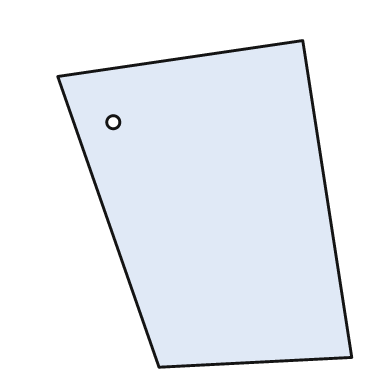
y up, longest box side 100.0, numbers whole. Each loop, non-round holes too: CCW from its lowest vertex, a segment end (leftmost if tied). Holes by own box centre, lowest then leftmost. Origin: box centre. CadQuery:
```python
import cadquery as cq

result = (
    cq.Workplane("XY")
    .moveTo(-14.0, -50.0)
    .lineTo(45.0, -47.0)
    .lineTo(30.0, 50.0)
    .lineTo(-45.0, 39.0)
    .close()
    .moveTo(-28.0, 25.0)
    .circle(2.0)
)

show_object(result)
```